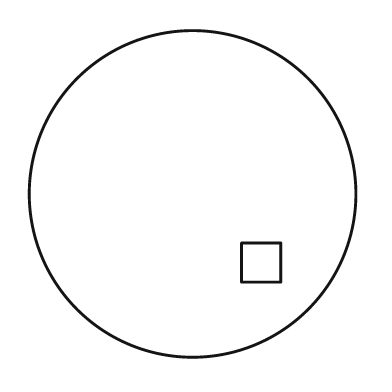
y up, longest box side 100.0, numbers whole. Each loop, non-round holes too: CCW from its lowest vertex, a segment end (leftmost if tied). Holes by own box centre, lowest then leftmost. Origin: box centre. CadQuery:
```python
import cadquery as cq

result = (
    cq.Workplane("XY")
    .moveTo(0.0, 0.0)
    .circle(50.0)
    .moveTo(15.0, -27.0)
    .lineTo(27.0, -27.0)
    .lineTo(27.0, -15.0)
    .lineTo(15.0, -15.0)
    .close()
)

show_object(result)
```